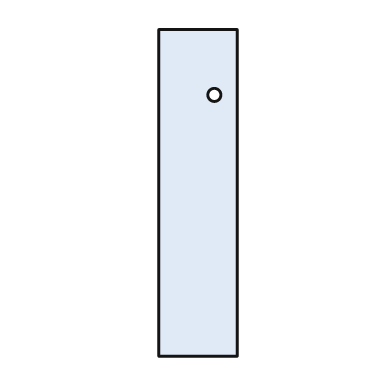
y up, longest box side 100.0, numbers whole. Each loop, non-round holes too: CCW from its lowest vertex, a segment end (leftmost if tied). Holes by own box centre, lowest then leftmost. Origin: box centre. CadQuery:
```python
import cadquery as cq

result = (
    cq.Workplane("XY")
    .moveTo(-12.0, -50.0)
    .lineTo(12.0, -50.0)
    .lineTo(12.0, 50.0)
    .lineTo(-12.0, 50.0)
    .close()
    .moveTo(5.0, 30.0)
    .circle(2.0)
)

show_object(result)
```